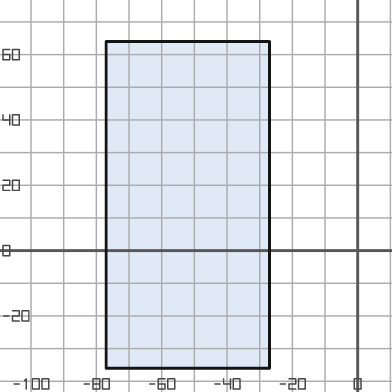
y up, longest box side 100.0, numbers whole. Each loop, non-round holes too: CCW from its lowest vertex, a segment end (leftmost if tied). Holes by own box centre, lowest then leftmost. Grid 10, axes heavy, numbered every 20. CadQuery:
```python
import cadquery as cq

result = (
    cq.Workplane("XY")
    .moveTo(-77.0, -36.0)
    .lineTo(-27.0, -36.0)
    .lineTo(-27.0, 64.0)
    .lineTo(-77.0, 64.0)
    .close()
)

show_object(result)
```